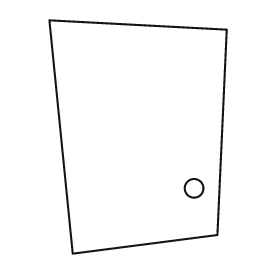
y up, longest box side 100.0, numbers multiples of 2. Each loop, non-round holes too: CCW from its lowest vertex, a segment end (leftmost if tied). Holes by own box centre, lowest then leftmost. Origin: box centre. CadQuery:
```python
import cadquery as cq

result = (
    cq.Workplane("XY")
    .moveTo(-28.0, -50.0)
    .lineTo(34.0, -42.0)
    .lineTo(38.0, 46.0)
    .lineTo(-38.0, 50.0)
    .close()
    .moveTo(24.0, -22.0)
    .circle(4.0)
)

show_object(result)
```